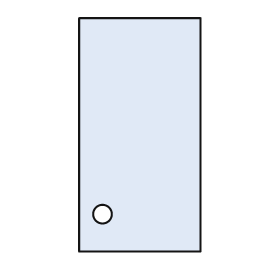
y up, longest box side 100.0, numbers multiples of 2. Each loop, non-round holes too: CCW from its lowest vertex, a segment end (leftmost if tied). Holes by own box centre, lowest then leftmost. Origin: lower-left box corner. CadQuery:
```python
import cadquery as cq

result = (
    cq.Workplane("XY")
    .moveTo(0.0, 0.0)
    .lineTo(52.0, 0.0)
    .lineTo(52.0, 100.0)
    .lineTo(0.0, 100.0)
    .close()
    .moveTo(10.0, 16.0)
    .circle(4.0)
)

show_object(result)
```